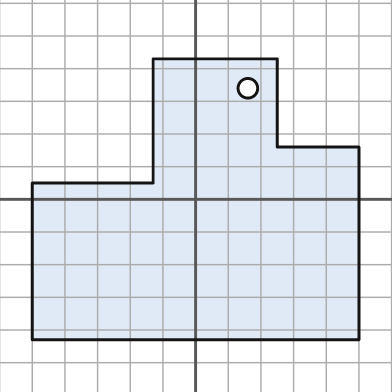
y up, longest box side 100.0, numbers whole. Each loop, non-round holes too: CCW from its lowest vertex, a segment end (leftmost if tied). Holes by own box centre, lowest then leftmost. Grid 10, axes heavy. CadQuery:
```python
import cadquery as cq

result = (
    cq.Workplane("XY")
    .moveTo(-50.0, -43.0)
    .lineTo(50.0, -43.0)
    .lineTo(50.0, 16.0)
    .lineTo(25.0, 16.0)
    .lineTo(25.0, 43.0)
    .lineTo(-13.0, 43.0)
    .lineTo(-13.0, 5.0)
    .lineTo(-50.0, 5.0)
    .close()
    .moveTo(16.0, 34.0)
    .circle(3.0)
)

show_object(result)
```